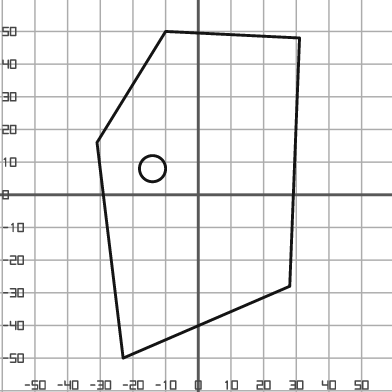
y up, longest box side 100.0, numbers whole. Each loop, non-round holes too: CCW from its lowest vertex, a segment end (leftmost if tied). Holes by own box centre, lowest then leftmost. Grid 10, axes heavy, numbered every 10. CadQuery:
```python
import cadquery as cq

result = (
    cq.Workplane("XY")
    .moveTo(-23.0, -50.0)
    .lineTo(28.0, -28.0)
    .lineTo(31.0, 48.0)
    .lineTo(-10.0, 50.0)
    .lineTo(-31.0, 16.0)
    .close()
    .moveTo(-14.0, 8.0)
    .circle(4.0)
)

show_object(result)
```